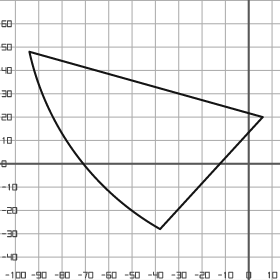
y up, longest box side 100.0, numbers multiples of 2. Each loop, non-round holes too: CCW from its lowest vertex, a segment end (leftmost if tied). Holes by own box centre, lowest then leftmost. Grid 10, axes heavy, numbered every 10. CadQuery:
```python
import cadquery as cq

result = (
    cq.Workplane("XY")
    .moveTo(-38.0, -28.0)
    .lineTo(6.0, 20.0)
    .lineTo(-94.0, 48.0)
    .threePointArc((-74.0, 4.0), (-38.0, -28.0))
    .close()
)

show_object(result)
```